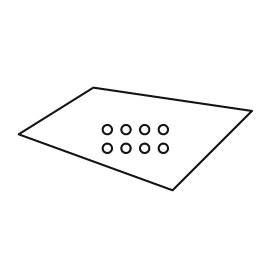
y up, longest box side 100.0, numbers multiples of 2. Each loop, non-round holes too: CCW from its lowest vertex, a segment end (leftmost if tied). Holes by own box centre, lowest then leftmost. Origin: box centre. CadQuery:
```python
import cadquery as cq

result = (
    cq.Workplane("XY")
    .moveTo(16.0, -22.0)
    .lineTo(50.0, 12.0)
    .lineTo(-18.0, 22.0)
    .lineTo(-50.0, 2.0)
    .close()
    .moveTo(-12.0, -4.0)
    .circle(2.0)
    .moveTo(-4.0, -4.0)
    .circle(2.0)
    .moveTo(4.0, -4.0)
    .circle(2.0)
    .moveTo(12.0, -4.0)
    .circle(2.0)
    .moveTo(-12.0, 4.0)
    .circle(2.0)
    .moveTo(-4.0, 4.0)
    .circle(2.0)
    .moveTo(4.0, 4.0)
    .circle(2.0)
    .moveTo(12.0, 4.0)
    .circle(2.0)
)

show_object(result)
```